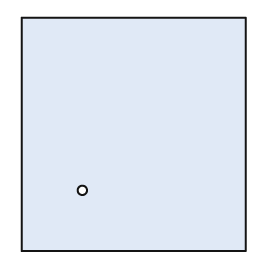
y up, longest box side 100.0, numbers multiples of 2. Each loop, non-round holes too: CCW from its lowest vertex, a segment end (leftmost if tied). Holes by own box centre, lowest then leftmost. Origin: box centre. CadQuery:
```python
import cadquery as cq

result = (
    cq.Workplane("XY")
    .moveTo(-48.0, -50.0)
    .lineTo(48.0, -50.0)
    .lineTo(48.0, 50.0)
    .lineTo(-48.0, 50.0)
    .close()
    .moveTo(-22.0, -24.0)
    .circle(2.0)
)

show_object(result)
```